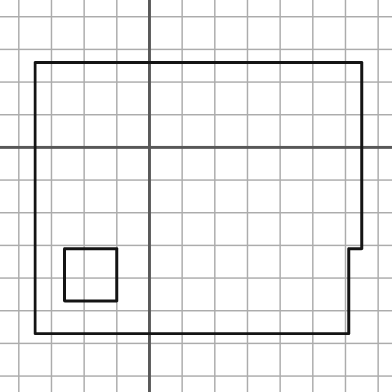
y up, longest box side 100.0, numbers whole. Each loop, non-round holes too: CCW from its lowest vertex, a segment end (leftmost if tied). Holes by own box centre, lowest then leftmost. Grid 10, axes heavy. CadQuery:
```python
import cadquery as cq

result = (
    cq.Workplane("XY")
    .moveTo(-35.0, -57.0)
    .lineTo(61.0, -57.0)
    .lineTo(61.0, -31.0)
    .lineTo(65.0, -31.0)
    .lineTo(65.0, 26.0)
    .lineTo(-35.0, 26.0)
    .close()
    .moveTo(-26.0, -47.0)
    .lineTo(-10.0, -47.0)
    .lineTo(-10.0, -31.0)
    .lineTo(-26.0, -31.0)
    .close()
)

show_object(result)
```